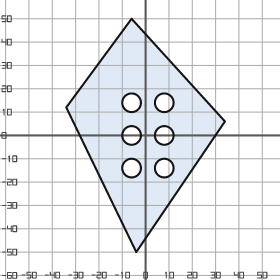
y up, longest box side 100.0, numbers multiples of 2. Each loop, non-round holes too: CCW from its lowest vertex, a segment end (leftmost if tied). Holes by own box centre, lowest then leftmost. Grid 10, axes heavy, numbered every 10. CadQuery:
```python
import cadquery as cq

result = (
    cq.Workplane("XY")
    .moveTo(-4.0, -50.0)
    .lineTo(34.0, 6.0)
    .lineTo(-6.0, 50.0)
    .lineTo(-34.0, 12.0)
    .close()
    .moveTo(-6.0, -14.0)
    .circle(4.0)
    .moveTo(8.0, -14.0)
    .circle(4.0)
    .moveTo(-6.0, 0.0)
    .circle(4.0)
    .moveTo(8.0, 0.0)
    .circle(4.0)
    .moveTo(-6.0, 14.0)
    .circle(4.0)
    .moveTo(8.0, 14.0)
    .circle(4.0)
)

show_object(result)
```